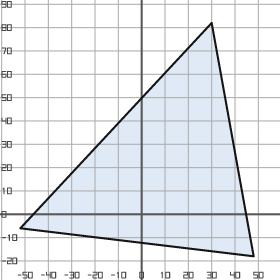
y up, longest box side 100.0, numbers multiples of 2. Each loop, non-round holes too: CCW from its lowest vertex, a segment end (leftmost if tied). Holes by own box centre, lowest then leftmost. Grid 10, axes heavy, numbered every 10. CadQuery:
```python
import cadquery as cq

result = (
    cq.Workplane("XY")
    .moveTo(48.0, -18.0)
    .lineTo(30.0, 82.0)
    .lineTo(-52.0, -6.0)
    .close()
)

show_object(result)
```